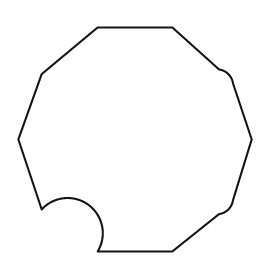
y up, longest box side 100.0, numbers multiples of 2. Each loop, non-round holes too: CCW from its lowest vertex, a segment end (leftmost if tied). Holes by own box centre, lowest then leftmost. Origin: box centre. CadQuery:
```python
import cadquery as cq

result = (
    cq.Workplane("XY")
    .moveTo(-16.0, -48.0)
    .lineTo(16.0, -48.0)
    .lineTo(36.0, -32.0)
    .threePointArc((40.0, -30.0), (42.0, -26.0))
    .lineTo(50.0, 0.0)
    .lineTo(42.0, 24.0)
    .threePointArc((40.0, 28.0), (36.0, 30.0))
    .lineTo(16.0, 48.0)
    .lineTo(-16.0, 48.0)
    .lineTo(-40.0, 28.0)
    .lineTo(-50.0, 0.0)
    .lineTo(-40.0, -30.0)
    .threePointArc((-20.0, -28.0), (-16.0, -48.0))
    .close()
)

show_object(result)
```